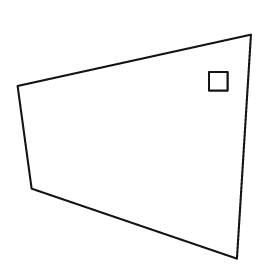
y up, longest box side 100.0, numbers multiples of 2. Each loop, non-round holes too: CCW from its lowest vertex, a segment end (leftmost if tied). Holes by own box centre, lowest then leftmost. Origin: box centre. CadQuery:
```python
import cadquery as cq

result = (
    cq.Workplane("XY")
    .moveTo(44.0, -48.0)
    .lineTo(50.0, 48.0)
    .lineTo(-50.0, 26.0)
    .lineTo(-44.0, -18.0)
    .close()
    .moveTo(32.0, 24.0)
    .lineTo(40.0, 24.0)
    .lineTo(40.0, 32.0)
    .lineTo(32.0, 32.0)
    .close()
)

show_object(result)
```